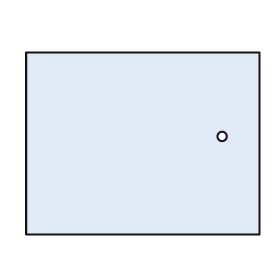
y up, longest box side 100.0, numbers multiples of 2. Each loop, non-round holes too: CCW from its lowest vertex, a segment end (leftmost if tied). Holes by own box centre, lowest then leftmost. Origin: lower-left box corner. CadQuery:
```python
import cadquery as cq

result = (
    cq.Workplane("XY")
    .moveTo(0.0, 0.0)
    .lineTo(100.0, 0.0)
    .lineTo(100.0, 78.0)
    .lineTo(0.0, 78.0)
    .close()
    .moveTo(84.0, 42.0)
    .circle(2.0)
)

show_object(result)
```